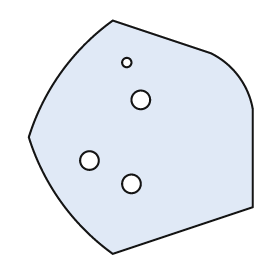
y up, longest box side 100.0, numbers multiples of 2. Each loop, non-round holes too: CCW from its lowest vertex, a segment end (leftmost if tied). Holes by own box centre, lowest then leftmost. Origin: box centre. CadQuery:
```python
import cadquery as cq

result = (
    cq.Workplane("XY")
    .moveTo(-12.0, -50.0)
    .lineTo(48.0, -30.0)
    .lineTo(48.0, 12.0)
    .threePointArc((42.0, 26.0), (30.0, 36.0))
    .lineTo(-12.0, 50.0)
    .threePointArc((-34.0, 28.0), (-48.0, 0.0))
    .threePointArc((-34.0, -28.0), (-12.0, -50.0))
    .close()
    .moveTo(-4.0, -20.0)
    .circle(4.0)
    .moveTo(-22.0, -10.0)
    .circle(4.0)
    .moveTo(0.0, 16.0)
    .circle(4.0)
    .moveTo(-6.0, 32.0)
    .circle(2.0)
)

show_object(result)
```